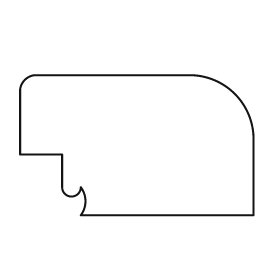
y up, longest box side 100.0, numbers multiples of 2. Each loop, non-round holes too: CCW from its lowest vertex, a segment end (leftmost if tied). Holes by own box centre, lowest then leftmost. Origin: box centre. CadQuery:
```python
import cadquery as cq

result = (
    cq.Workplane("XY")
    .moveTo(-24.0, -30.0)
    .lineTo(50.0, -30.0)
    .lineTo(50.0, 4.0)
    .threePointArc((42.0, 22.0), (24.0, 30.0))
    .lineTo(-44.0, 30.0)
    .threePointArc((-48.0, 28.0), (-50.0, 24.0))
    .lineTo(-50.0, -4.0)
    .lineTo(-32.0, -4.0)
    .lineTo(-32.0, -18.0)
    .threePointArc((-28.0, -22.0), (-24.0, -18.0))
    .threePointArc((-22.0, -24.0), (-24.0, -30.0))
    .close()
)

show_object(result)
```